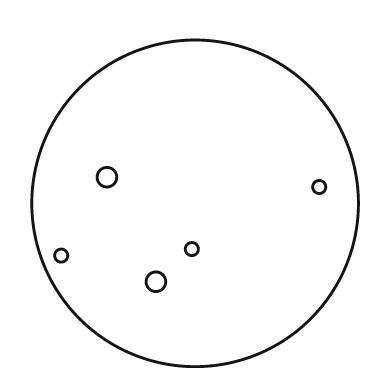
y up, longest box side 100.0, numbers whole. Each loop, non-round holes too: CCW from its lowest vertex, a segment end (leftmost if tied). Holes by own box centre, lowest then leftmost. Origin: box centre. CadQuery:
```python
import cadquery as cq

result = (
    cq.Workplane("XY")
    .moveTo(0.0, 0.0)
    .circle(50.0)
    .moveTo(-12.0, -24.0)
    .circle(3.0)
    .moveTo(-41.0, -16.0)
    .circle(2.0)
    .moveTo(-1.0, -14.0)
    .circle(2.0)
    .moveTo(38.0, 5.0)
    .circle(2.0)
    .moveTo(-27.0, 8.0)
    .circle(3.0)
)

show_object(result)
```